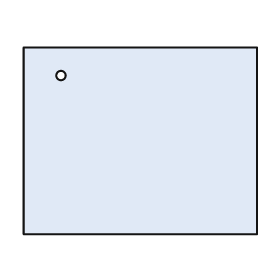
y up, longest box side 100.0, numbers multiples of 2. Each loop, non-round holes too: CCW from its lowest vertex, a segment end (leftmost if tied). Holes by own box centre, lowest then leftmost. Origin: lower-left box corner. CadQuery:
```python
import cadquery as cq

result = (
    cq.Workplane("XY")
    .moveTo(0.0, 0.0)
    .lineTo(100.0, 0.0)
    .lineTo(100.0, 80.0)
    .lineTo(0.0, 80.0)
    .close()
    .moveTo(16.0, 68.0)
    .circle(2.0)
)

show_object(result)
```